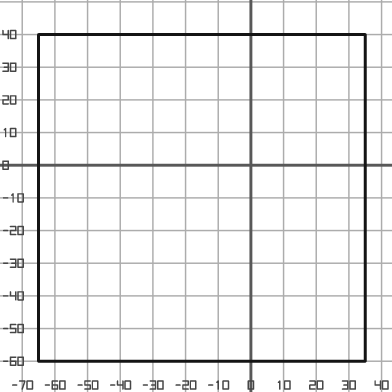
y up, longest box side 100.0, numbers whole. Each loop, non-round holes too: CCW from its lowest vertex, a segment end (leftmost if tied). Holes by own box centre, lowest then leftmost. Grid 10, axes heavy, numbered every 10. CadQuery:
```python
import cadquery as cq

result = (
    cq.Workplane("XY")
    .moveTo(-65.0, -60.0)
    .lineTo(35.0, -60.0)
    .lineTo(35.0, 40.0)
    .lineTo(-65.0, 40.0)
    .close()
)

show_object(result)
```